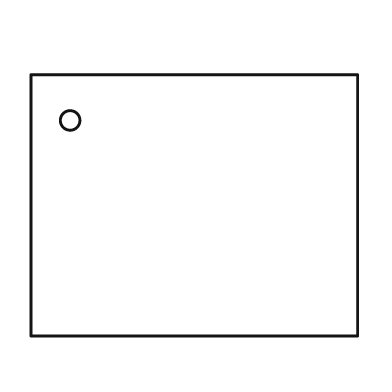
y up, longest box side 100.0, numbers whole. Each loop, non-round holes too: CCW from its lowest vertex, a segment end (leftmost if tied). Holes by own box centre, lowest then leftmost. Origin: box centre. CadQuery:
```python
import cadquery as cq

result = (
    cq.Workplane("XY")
    .moveTo(-50.0, -40.0)
    .lineTo(50.0, -40.0)
    .lineTo(50.0, 40.0)
    .lineTo(-50.0, 40.0)
    .close()
    .moveTo(-38.0, 26.0)
    .circle(3.0)
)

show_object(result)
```